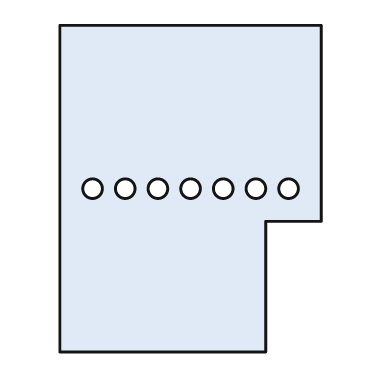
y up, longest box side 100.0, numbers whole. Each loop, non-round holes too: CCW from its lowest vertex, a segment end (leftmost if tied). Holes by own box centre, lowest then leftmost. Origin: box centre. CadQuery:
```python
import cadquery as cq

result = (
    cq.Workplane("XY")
    .moveTo(-40.0, -50.0)
    .lineTo(23.0, -50.0)
    .lineTo(23.0, -10.0)
    .lineTo(40.0, -10.0)
    .lineTo(40.0, 50.0)
    .lineTo(-40.0, 50.0)
    .close()
    .moveTo(-30.0, 0.0)
    .circle(3.0)
    .moveTo(-20.0, 0.0)
    .circle(3.0)
    .moveTo(-10.0, 0.0)
    .circle(3.0)
    .moveTo(0.0, 0.0)
    .circle(3.0)
    .moveTo(10.0, 0.0)
    .circle(3.0)
    .moveTo(20.0, 0.0)
    .circle(3.0)
    .moveTo(30.0, 0.0)
    .circle(3.0)
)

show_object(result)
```